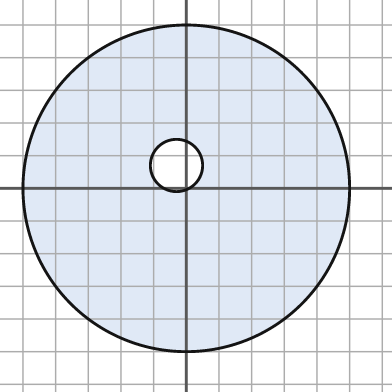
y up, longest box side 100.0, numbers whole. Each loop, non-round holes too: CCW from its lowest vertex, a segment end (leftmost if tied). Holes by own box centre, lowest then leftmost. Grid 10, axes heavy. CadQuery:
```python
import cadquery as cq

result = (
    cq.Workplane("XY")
    .moveTo(0.0, 0.0)
    .circle(50.0)
    .moveTo(-3.0, 7.0)
    .circle(8.0)
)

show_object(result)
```